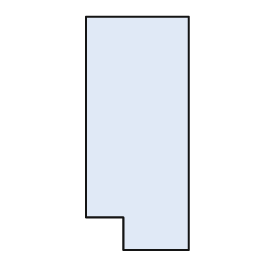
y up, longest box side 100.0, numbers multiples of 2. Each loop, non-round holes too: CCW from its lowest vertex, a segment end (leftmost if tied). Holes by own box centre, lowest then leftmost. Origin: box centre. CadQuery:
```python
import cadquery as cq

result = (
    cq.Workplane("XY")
    .moveTo(-6.0, -50.0)
    .lineTo(22.0, -50.0)
    .lineTo(22.0, 50.0)
    .lineTo(-22.0, 50.0)
    .lineTo(-22.0, -36.0)
    .lineTo(-6.0, -36.0)
    .close()
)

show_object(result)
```